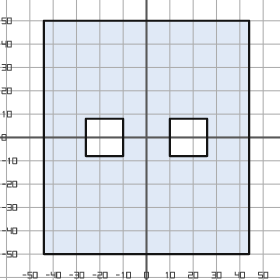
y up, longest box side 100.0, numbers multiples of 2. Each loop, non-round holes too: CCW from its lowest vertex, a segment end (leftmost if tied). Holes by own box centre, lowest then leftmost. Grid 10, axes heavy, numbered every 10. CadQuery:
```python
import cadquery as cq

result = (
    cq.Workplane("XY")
    .moveTo(-44.0, -50.0)
    .lineTo(44.0, -50.0)
    .lineTo(44.0, 50.0)
    .lineTo(-44.0, 50.0)
    .close()
    .moveTo(-26.0, -8.0)
    .lineTo(-10.0, -8.0)
    .lineTo(-10.0, 8.0)
    .lineTo(-26.0, 8.0)
    .close()
    .moveTo(10.0, -8.0)
    .lineTo(26.0, -8.0)
    .lineTo(26.0, 8.0)
    .lineTo(10.0, 8.0)
    .close()
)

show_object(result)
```